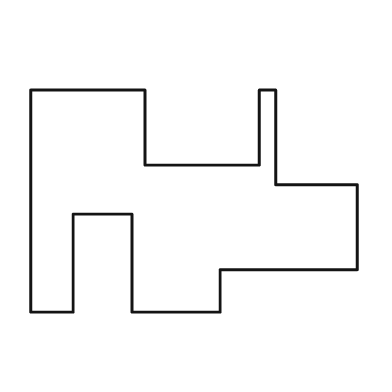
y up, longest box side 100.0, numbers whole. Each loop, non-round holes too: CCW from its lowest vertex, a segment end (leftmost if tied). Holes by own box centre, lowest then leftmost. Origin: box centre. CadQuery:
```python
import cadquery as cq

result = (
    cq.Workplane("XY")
    .moveTo(-50.0, -34.0)
    .lineTo(-37.0, -34.0)
    .lineTo(-37.0, -4.0)
    .lineTo(-19.0, -4.0)
    .lineTo(-19.0, -34.0)
    .lineTo(8.0, -34.0)
    .lineTo(8.0, -21.0)
    .lineTo(50.0, -21.0)
    .lineTo(50.0, 5.0)
    .lineTo(25.0, 5.0)
    .lineTo(25.0, 34.0)
    .lineTo(20.0, 34.0)
    .lineTo(20.0, 11.0)
    .lineTo(-15.0, 11.0)
    .lineTo(-15.0, 34.0)
    .lineTo(-50.0, 34.0)
    .close()
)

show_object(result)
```